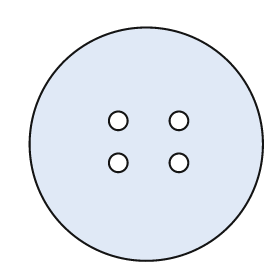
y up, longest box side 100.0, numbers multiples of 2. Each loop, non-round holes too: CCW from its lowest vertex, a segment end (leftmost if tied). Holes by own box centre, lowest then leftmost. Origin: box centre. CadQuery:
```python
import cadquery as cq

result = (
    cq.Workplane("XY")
    .moveTo(0.0, 0.0)
    .circle(50.0)
    .moveTo(-12.0, -8.0)
    .circle(4.0)
    .moveTo(14.0, -8.0)
    .circle(4.0)
    .moveTo(-12.0, 10.0)
    .circle(4.0)
    .moveTo(14.0, 10.0)
    .circle(4.0)
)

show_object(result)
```